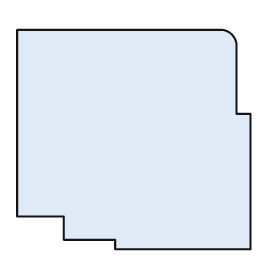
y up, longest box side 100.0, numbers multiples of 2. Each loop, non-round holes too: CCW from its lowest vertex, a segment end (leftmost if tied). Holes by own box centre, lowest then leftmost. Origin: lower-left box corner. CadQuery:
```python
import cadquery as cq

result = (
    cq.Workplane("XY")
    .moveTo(42.0, 0.0)
    .lineTo(100.0, 0.0)
    .lineTo(100.0, 58.0)
    .lineTo(94.0, 58.0)
    .lineTo(94.0, 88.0)
    .threePointArc((92.0, 92.0), (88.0, 94.0))
    .lineTo(0.0, 94.0)
    .lineTo(0.0, 14.0)
    .lineTo(20.0, 14.0)
    .lineTo(20.0, 4.0)
    .lineTo(42.0, 4.0)
    .close()
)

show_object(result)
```